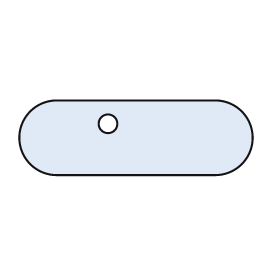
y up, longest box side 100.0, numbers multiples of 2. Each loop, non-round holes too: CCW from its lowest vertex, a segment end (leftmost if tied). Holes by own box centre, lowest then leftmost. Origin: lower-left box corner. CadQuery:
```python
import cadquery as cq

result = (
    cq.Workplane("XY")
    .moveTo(16.0, 0.0)
    .lineTo(84.0, 0.0)
    .threePointArc((100.0, 16.0), (84.0, 32.0))
    .lineTo(16.0, 32.0)
    .threePointArc((0.0, 16.0), (16.0, 0.0))
    .close()
    .moveTo(38.0, 22.0)
    .circle(4.0)
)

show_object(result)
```